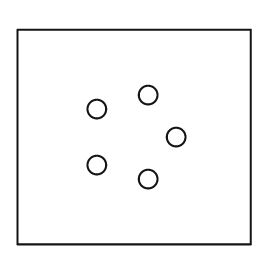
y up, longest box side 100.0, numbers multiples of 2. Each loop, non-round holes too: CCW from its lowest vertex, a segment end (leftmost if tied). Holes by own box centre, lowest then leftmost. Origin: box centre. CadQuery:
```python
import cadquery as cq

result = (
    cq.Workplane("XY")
    .moveTo(-50.0, -46.0)
    .lineTo(50.0, -46.0)
    .lineTo(50.0, 46.0)
    .lineTo(-50.0, 46.0)
    .close()
    .moveTo(6.0, -18.0)
    .circle(4.0)
    .moveTo(-16.0, -12.0)
    .circle(4.0)
    .moveTo(18.0, 0.0)
    .circle(4.0)
    .moveTo(-16.0, 12.0)
    .circle(4.0)
    .moveTo(6.0, 18.0)
    .circle(4.0)
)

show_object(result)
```